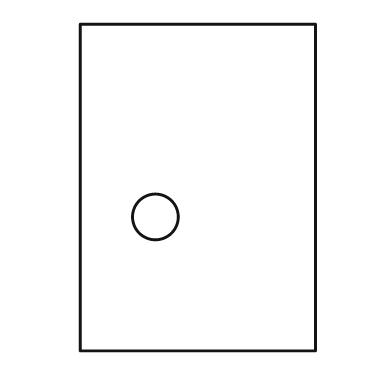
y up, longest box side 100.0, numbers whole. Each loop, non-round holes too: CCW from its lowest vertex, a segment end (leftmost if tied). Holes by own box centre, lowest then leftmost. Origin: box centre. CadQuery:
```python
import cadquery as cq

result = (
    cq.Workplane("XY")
    .moveTo(-36.0, -50.0)
    .lineTo(36.0, -50.0)
    .lineTo(36.0, 50.0)
    .lineTo(-36.0, 50.0)
    .close()
    .moveTo(-13.0, -9.0)
    .circle(7.0)
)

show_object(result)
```